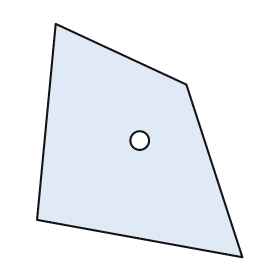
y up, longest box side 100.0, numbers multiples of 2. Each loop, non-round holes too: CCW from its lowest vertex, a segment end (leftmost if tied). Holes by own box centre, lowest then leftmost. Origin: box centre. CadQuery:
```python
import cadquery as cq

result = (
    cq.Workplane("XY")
    .moveTo(44.0, -50.0)
    .lineTo(20.0, 24.0)
    .lineTo(-36.0, 50.0)
    .lineTo(-44.0, -34.0)
    .close()
    .moveTo(0.0, 0.0)
    .circle(4.0)
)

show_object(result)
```